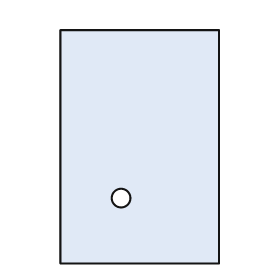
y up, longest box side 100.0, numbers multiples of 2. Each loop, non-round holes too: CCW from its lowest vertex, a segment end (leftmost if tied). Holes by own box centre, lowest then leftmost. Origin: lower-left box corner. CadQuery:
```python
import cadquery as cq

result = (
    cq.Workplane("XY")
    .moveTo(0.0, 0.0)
    .lineTo(68.0, 0.0)
    .lineTo(68.0, 100.0)
    .lineTo(0.0, 100.0)
    .close()
    .moveTo(26.0, 28.0)
    .circle(4.0)
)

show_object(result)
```